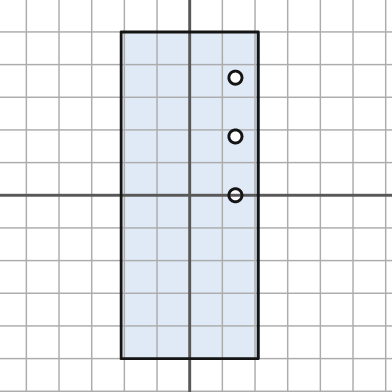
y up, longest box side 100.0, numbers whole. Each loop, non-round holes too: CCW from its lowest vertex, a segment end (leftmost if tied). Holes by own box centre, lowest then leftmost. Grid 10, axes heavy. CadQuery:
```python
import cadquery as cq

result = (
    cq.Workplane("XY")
    .moveTo(-21.0, -50.0)
    .lineTo(21.0, -50.0)
    .lineTo(21.0, 50.0)
    .lineTo(-21.0, 50.0)
    .close()
    .moveTo(14.0, 0.0)
    .circle(2.0)
    .moveTo(14.0, 18.0)
    .circle(2.0)
    .moveTo(14.0, 36.0)
    .circle(2.0)
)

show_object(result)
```